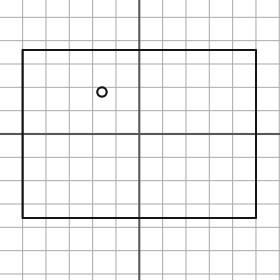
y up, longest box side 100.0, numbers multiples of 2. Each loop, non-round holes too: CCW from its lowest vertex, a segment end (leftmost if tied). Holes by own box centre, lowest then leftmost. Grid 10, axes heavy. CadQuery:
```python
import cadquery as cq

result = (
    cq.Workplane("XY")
    .moveTo(-50.0, -36.0)
    .lineTo(50.0, -36.0)
    .lineTo(50.0, 36.0)
    .lineTo(-50.0, 36.0)
    .close()
    .moveTo(-16.0, 18.0)
    .circle(2.0)
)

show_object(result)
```